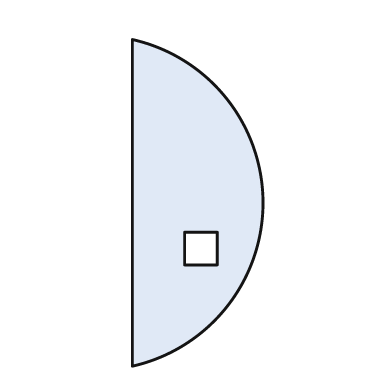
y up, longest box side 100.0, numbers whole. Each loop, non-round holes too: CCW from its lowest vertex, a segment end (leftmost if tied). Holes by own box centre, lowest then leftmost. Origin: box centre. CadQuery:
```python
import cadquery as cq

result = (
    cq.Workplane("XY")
    .moveTo(-20.0, -50.0)
    .threePointArc((20.0, 0.0), (-20.0, 50.0))
    .close()
    .moveTo(-4.0, -19.0)
    .lineTo(6.0, -19.0)
    .lineTo(6.0, -9.0)
    .lineTo(-4.0, -9.0)
    .close()
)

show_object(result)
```